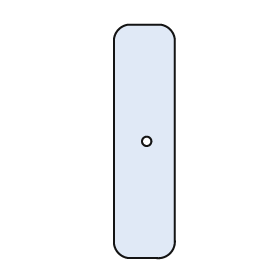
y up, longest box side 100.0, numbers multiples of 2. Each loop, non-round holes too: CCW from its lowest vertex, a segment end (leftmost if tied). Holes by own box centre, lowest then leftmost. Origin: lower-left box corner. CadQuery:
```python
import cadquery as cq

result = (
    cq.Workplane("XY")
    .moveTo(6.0, 0.0)
    .lineTo(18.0, 0.0)
    .threePointArc((24.0, 2.0), (26.0, 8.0))
    .lineTo(26.0, 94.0)
    .threePointArc((24.0, 98.0), (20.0, 100.0))
    .lineTo(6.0, 100.0)
    .threePointArc((2.0, 98.0), (0.0, 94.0))
    .lineTo(0.0, 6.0)
    .threePointArc((2.0, 2.0), (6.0, 0.0))
    .close()
    .moveTo(14.0, 50.0)
    .circle(2.0)
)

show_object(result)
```